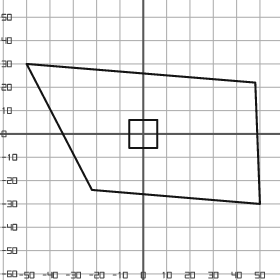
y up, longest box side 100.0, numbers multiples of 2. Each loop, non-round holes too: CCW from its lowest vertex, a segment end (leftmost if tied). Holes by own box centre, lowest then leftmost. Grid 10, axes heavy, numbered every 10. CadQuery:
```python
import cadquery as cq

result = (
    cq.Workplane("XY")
    .moveTo(50.0, -30.0)
    .lineTo(48.0, 22.0)
    .lineTo(-50.0, 30.0)
    .lineTo(-22.0, -24.0)
    .close()
    .moveTo(-6.0, -6.0)
    .lineTo(6.0, -6.0)
    .lineTo(6.0, 6.0)
    .lineTo(-6.0, 6.0)
    .close()
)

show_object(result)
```